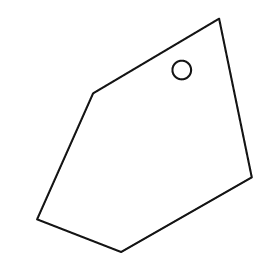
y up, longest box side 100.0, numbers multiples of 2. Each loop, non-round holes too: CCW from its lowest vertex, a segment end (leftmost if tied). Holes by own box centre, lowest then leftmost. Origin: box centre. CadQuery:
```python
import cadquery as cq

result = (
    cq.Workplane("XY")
    .moveTo(-10.0, -50.0)
    .lineTo(46.0, -18.0)
    .lineTo(32.0, 50.0)
    .lineTo(-22.0, 18.0)
    .lineTo(-46.0, -36.0)
    .close()
    .moveTo(16.0, 28.0)
    .circle(4.0)
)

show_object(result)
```